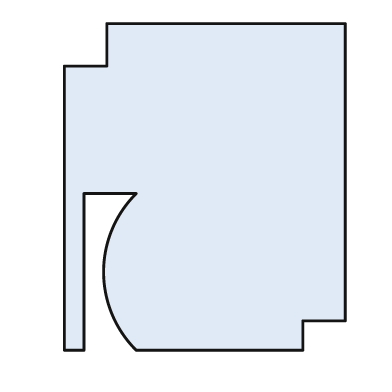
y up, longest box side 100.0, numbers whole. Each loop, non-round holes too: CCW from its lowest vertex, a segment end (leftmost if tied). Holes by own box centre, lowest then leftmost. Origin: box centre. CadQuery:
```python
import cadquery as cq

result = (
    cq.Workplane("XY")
    .moveTo(-43.0, -50.0)
    .lineTo(-37.0, -50.0)
    .lineTo(-37.0, -2.0)
    .lineTo(-21.0, -2.0)
    .threePointArc((-31.0, -26.0), (-21.0, -50.0))
    .lineTo(30.0, -50.0)
    .lineTo(30.0, -41.0)
    .lineTo(43.0, -41.0)
    .lineTo(43.0, 50.0)
    .lineTo(-30.0, 50.0)
    .lineTo(-30.0, 37.0)
    .lineTo(-43.0, 37.0)
    .close()
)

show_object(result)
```